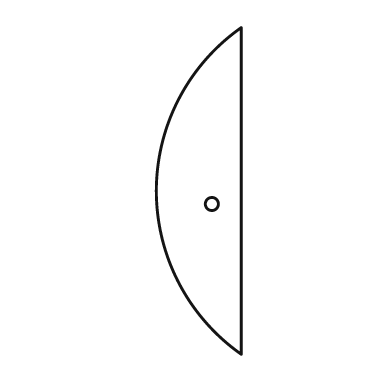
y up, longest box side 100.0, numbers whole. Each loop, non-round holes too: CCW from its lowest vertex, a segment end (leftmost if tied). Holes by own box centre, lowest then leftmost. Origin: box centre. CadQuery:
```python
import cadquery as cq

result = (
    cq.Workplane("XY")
    .moveTo(13.0, -50.0)
    .lineTo(13.0, 50.0)
    .threePointArc((-13.0, 0.0), (13.0, -50.0))
    .close()
    .moveTo(4.0, -4.0)
    .circle(2.0)
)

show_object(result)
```